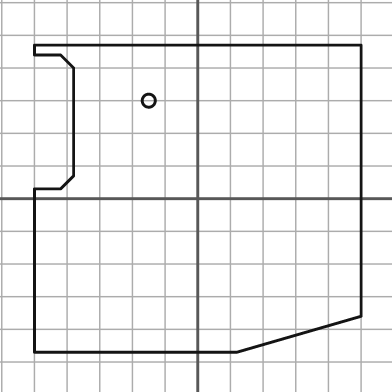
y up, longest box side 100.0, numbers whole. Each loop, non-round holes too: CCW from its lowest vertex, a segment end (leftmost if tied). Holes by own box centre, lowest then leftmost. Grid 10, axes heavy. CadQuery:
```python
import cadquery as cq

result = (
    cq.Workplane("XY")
    .moveTo(-50.0, -47.0)
    .lineTo(12.0, -47.0)
    .lineTo(50.0, -36.0)
    .lineTo(50.0, 47.0)
    .lineTo(-50.0, 47.0)
    .lineTo(-50.0, 44.0)
    .lineTo(-42.0, 44.0)
    .lineTo(-38.0, 40.0)
    .lineTo(-38.0, 7.0)
    .lineTo(-42.0, 3.0)
    .lineTo(-50.0, 3.0)
    .close()
    .moveTo(-15.0, 30.0)
    .circle(2.0)
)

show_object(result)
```